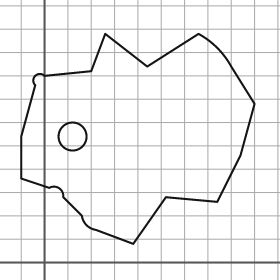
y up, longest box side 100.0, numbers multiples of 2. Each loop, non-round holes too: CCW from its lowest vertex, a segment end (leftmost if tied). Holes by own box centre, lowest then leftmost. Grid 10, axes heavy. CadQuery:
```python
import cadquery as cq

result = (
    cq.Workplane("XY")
    .moveTo(38.0, 8.0)
    .lineTo(52.0, 28.0)
    .lineTo(74.0, 26.0)
    .lineTo(84.0, 46.0)
    .lineTo(90.0, 68.0)
    .lineTo(80.0, 84.0)
    .threePointArc((74.0, 92.0), (66.0, 98.0))
    .lineTo(44.0, 84.0)
    .lineTo(26.0, 98.0)
    .lineTo(20.0, 82.0)
    .lineTo(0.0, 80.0)
    .threePointArc((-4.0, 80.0), (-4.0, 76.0))
    .lineTo(-10.0, 54.0)
    .lineTo(-10.0, 36.0)
    .lineTo(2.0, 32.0)
    .threePointArc((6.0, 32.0), (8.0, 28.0))
    .lineTo(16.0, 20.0)
    .threePointArc((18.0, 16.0), (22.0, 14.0))
    .close()
    .moveTo(12.0, 54.0)
    .circle(6.0)
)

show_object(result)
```